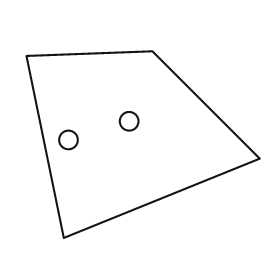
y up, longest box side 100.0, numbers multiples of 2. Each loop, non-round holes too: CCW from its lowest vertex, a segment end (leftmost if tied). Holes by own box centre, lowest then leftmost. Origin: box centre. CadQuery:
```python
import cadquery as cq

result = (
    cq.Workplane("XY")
    .moveTo(-34.0, -40.0)
    .lineTo(50.0, -6.0)
    .lineTo(4.0, 40.0)
    .lineTo(-50.0, 38.0)
    .close()
    .moveTo(-32.0, 2.0)
    .circle(4.0)
    .moveTo(-6.0, 10.0)
    .circle(4.0)
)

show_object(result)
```